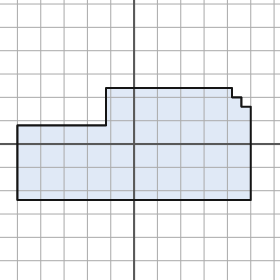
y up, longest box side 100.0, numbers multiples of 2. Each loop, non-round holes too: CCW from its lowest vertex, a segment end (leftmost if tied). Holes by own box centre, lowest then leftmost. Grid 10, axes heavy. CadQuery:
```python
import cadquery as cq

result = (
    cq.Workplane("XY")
    .moveTo(-50.0, -24.0)
    .lineTo(50.0, -24.0)
    .lineTo(50.0, 16.0)
    .lineTo(46.0, 16.0)
    .lineTo(46.0, 20.0)
    .lineTo(42.0, 20.0)
    .lineTo(42.0, 24.0)
    .lineTo(-12.0, 24.0)
    .lineTo(-12.0, 8.0)
    .lineTo(-50.0, 8.0)
    .close()
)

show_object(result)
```